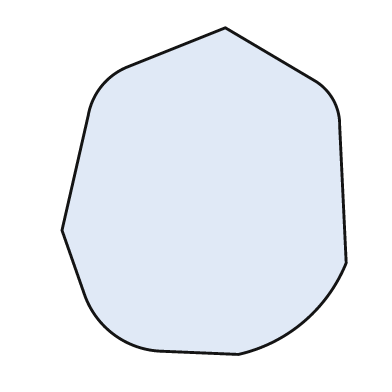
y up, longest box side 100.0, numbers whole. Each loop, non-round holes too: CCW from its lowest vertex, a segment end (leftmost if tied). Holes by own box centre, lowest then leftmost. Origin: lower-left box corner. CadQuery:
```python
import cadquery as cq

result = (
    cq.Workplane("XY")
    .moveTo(54.0, 0.0)
    .threePointArc((74.0, 10.0), (87.0, 28.0))
    .lineTo(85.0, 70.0)
    .threePointArc((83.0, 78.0), (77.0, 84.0))
    .lineTo(50.0, 100.0)
    .lineTo(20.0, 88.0)
    .threePointArc((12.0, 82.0), (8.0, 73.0))
    .lineTo(0.0, 38.0)
    .lineTo(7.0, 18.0)
    .threePointArc((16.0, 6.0), (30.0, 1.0))
    .close()
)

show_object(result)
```